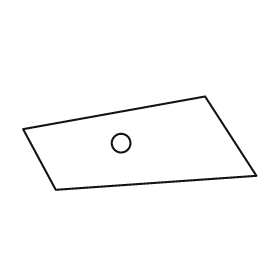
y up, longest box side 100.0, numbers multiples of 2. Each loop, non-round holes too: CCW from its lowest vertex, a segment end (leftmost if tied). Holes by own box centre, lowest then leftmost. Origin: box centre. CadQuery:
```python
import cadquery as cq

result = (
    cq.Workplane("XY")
    .moveTo(-36.0, -20.0)
    .lineTo(50.0, -14.0)
    .lineTo(28.0, 20.0)
    .lineTo(-50.0, 6.0)
    .close()
    .moveTo(-8.0, 0.0)
    .circle(4.0)
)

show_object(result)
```